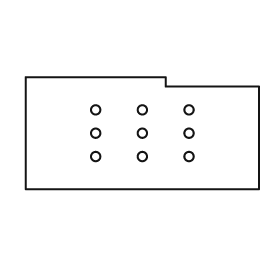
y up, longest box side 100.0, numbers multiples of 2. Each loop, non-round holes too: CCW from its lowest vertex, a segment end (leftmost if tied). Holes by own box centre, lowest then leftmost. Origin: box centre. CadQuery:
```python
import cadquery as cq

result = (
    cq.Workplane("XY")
    .moveTo(-50.0, -24.0)
    .lineTo(50.0, -24.0)
    .lineTo(50.0, 20.0)
    .lineTo(10.0, 20.0)
    .lineTo(10.0, 24.0)
    .lineTo(-50.0, 24.0)
    .close()
    .moveTo(-20.0, -10.0)
    .circle(2.0)
    .moveTo(0.0, -10.0)
    .circle(2.0)
    .moveTo(20.0, -10.0)
    .circle(2.0)
    .moveTo(-20.0, 0.0)
    .circle(2.0)
    .moveTo(0.0, 0.0)
    .circle(2.0)
    .moveTo(20.0, 0.0)
    .circle(2.0)
    .moveTo(-20.0, 10.0)
    .circle(2.0)
    .moveTo(0.0, 10.0)
    .circle(2.0)
    .moveTo(20.0, 10.0)
    .circle(2.0)
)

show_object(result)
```